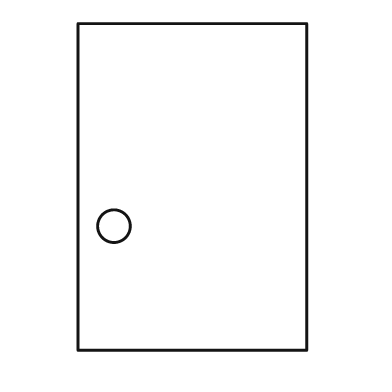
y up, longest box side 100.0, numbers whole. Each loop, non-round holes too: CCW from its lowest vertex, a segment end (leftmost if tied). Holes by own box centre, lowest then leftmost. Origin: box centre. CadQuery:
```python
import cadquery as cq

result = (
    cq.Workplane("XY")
    .moveTo(-35.0, -50.0)
    .lineTo(35.0, -50.0)
    .lineTo(35.0, 50.0)
    .lineTo(-35.0, 50.0)
    .close()
    .moveTo(-24.0, -12.0)
    .circle(5.0)
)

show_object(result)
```